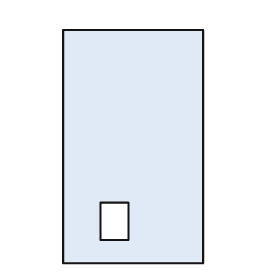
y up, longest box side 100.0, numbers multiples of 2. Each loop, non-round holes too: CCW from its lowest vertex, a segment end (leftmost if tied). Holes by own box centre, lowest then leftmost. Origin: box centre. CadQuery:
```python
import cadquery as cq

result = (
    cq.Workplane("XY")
    .moveTo(-30.0, -50.0)
    .lineTo(30.0, -50.0)
    .lineTo(30.0, 50.0)
    .lineTo(-30.0, 50.0)
    .close()
    .moveTo(-14.0, -40.0)
    .lineTo(-2.0, -40.0)
    .lineTo(-2.0, -24.0)
    .lineTo(-14.0, -24.0)
    .close()
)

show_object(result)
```